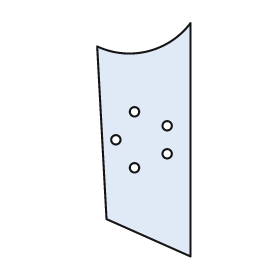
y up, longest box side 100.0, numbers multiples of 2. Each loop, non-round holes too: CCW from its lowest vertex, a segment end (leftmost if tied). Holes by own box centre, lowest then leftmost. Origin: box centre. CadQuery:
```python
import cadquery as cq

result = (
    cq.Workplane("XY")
    .moveTo(20.0, -50.0)
    .lineTo(20.0, 50.0)
    .threePointArc((2.0, 38.0), (-20.0, 40.0))
    .lineTo(-16.0, -34.0)
    .close()
    .moveTo(-4.0, -12.0)
    .circle(2.0)
    .moveTo(10.0, -6.0)
    .circle(2.0)
    .moveTo(-12.0, 0.0)
    .circle(2.0)
    .moveTo(10.0, 6.0)
    .circle(2.0)
    .moveTo(-4.0, 12.0)
    .circle(2.0)
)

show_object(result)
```